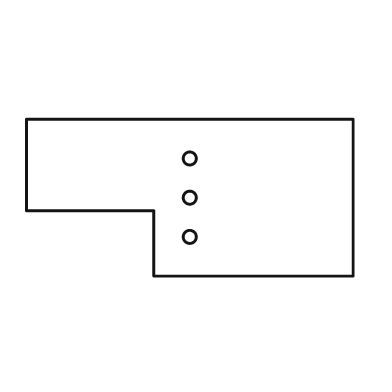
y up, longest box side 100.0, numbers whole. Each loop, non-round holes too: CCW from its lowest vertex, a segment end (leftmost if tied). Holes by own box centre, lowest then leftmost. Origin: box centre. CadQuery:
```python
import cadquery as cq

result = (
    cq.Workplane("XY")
    .moveTo(-11.0, -24.0)
    .lineTo(50.0, -24.0)
    .lineTo(50.0, 24.0)
    .lineTo(-50.0, 24.0)
    .lineTo(-50.0, -4.0)
    .lineTo(-11.0, -4.0)
    .close()
    .moveTo(0.0, -12.0)
    .circle(2.0)
    .moveTo(0.0, 0.0)
    .circle(2.0)
    .moveTo(0.0, 12.0)
    .circle(2.0)
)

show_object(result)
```